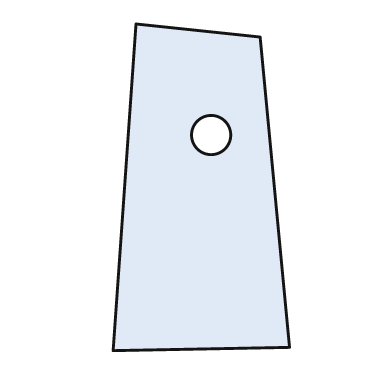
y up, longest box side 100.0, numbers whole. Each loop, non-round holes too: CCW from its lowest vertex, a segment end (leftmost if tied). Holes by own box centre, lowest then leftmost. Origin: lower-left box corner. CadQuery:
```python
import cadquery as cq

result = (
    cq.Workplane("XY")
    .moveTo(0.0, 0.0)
    .lineTo(54.0, 1.0)
    .lineTo(45.0, 96.0)
    .lineTo(7.0, 100.0)
    .close()
    .moveTo(30.0, 66.0)
    .circle(6.0)
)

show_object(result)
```